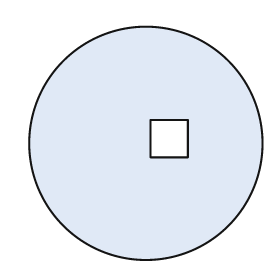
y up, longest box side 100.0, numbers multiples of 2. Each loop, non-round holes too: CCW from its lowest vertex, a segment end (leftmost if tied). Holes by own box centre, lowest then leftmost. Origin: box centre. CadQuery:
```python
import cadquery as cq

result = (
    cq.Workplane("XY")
    .moveTo(0.0, 0.0)
    .circle(50.0)
    .moveTo(2.0, -6.0)
    .lineTo(18.0, -6.0)
    .lineTo(18.0, 10.0)
    .lineTo(2.0, 10.0)
    .close()
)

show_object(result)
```